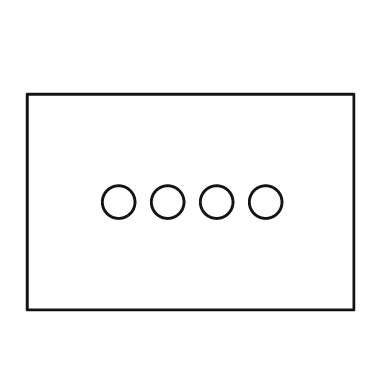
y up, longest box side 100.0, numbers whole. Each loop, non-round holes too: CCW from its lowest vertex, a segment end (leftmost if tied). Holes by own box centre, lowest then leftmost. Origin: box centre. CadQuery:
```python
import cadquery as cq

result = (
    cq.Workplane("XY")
    .moveTo(-50.0, -33.0)
    .lineTo(50.0, -33.0)
    .lineTo(50.0, 33.0)
    .lineTo(-50.0, 33.0)
    .close()
    .moveTo(-22.0, 0.0)
    .circle(5.0)
    .moveTo(-7.0, 0.0)
    .circle(5.0)
    .moveTo(8.0, 0.0)
    .circle(5.0)
    .moveTo(23.0, 0.0)
    .circle(5.0)
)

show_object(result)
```